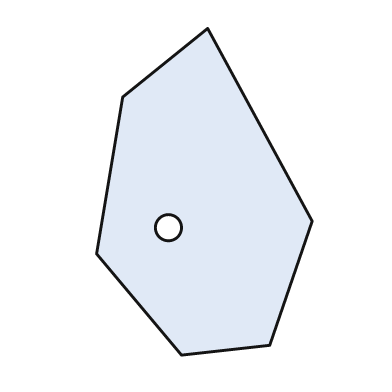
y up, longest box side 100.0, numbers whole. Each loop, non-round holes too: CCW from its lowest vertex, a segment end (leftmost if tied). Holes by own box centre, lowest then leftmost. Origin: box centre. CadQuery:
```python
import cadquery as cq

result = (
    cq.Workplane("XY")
    .moveTo(-7.0, -50.0)
    .lineTo(20.0, -47.0)
    .lineTo(33.0, -9.0)
    .lineTo(1.0, 50.0)
    .lineTo(-25.0, 29.0)
    .lineTo(-33.0, -19.0)
    .close()
    .moveTo(-11.0, -11.0)
    .circle(4.0)
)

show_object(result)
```